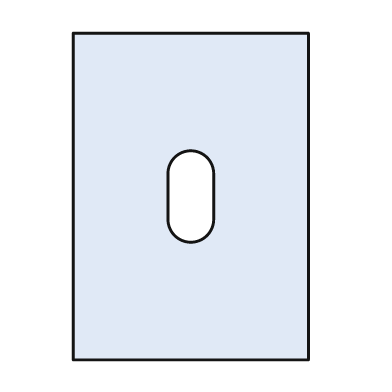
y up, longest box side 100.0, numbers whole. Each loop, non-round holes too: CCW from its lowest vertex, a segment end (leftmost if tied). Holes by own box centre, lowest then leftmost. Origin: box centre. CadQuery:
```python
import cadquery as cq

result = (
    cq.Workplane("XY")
    .moveTo(-36.0, -50.0)
    .lineTo(36.0, -50.0)
    .lineTo(36.0, 50.0)
    .lineTo(-36.0, 50.0)
    .close()
    .moveTo(-7.0, -7.0)
    .threePointArc((0.0, -14.0), (7.0, -7.0))
    .lineTo(7.0, 7.0)
    .threePointArc((0.0, 14.0), (-7.0, 7.0))
    .close()
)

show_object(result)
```